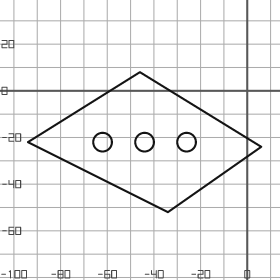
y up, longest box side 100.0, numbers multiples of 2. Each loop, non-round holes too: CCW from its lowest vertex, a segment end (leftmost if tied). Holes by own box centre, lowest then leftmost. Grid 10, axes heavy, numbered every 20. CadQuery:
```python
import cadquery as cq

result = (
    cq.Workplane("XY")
    .moveTo(-34.0, -52.0)
    .lineTo(6.0, -24.0)
    .lineTo(-46.0, 8.0)
    .lineTo(-94.0, -22.0)
    .close()
    .moveTo(-62.0, -22.0)
    .circle(4.0)
    .moveTo(-44.0, -22.0)
    .circle(4.0)
    .moveTo(-26.0, -22.0)
    .circle(4.0)
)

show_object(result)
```